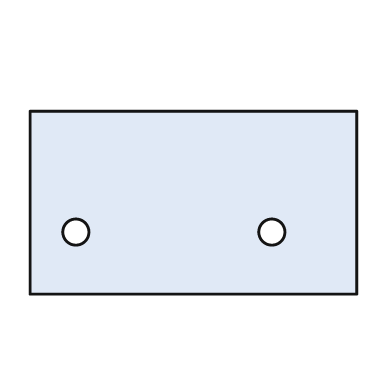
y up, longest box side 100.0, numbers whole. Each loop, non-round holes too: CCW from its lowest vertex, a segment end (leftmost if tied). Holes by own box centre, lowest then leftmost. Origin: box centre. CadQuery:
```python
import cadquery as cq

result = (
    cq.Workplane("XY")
    .moveTo(-50.0, -28.0)
    .lineTo(50.0, -28.0)
    .lineTo(50.0, 28.0)
    .lineTo(-50.0, 28.0)
    .close()
    .moveTo(-36.0, -9.0)
    .circle(4.0)
    .moveTo(24.0, -9.0)
    .circle(4.0)
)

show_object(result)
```